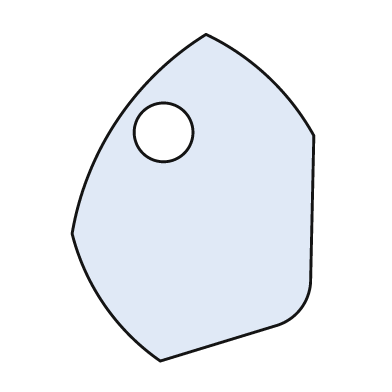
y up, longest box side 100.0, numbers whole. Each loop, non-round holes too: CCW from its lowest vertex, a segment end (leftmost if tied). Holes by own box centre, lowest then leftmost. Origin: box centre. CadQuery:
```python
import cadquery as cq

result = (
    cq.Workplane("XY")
    .moveTo(-10.0, -50.0)
    .lineTo(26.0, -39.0)
    .threePointArc((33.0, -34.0), (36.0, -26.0))
    .lineTo(37.0, 19.0)
    .threePointArc((23.0, 37.0), (4.0, 50.0))
    .threePointArc((-23.0, 24.0), (-37.0, -11.0))
    .threePointArc((-27.0, -33.0), (-10.0, -50.0))
    .close()
    .moveTo(-9.0, 20.0)
    .circle(9.0)
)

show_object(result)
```